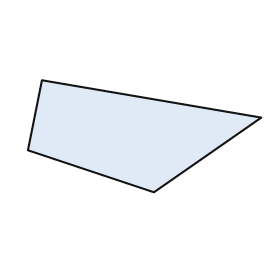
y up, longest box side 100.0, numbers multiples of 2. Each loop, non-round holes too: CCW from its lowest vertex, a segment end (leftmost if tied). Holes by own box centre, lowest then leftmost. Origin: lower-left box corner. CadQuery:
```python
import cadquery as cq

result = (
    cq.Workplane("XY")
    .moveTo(54.0, 0.0)
    .lineTo(100.0, 32.0)
    .lineTo(6.0, 48.0)
    .lineTo(0.0, 18.0)
    .close()
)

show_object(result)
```